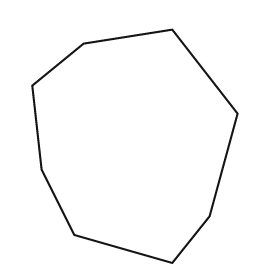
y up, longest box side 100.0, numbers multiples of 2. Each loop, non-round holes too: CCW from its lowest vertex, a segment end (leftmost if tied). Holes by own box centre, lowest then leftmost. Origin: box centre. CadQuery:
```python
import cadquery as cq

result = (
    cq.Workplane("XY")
    .moveTo(16.0, -50.0)
    .lineTo(32.0, -30.0)
    .lineTo(44.0, 14.0)
    .lineTo(16.0, 50.0)
    .lineTo(-22.0, 44.0)
    .lineTo(-44.0, 26.0)
    .lineTo(-40.0, -10.0)
    .lineTo(-26.0, -38.0)
    .close()
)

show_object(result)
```